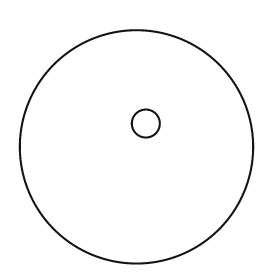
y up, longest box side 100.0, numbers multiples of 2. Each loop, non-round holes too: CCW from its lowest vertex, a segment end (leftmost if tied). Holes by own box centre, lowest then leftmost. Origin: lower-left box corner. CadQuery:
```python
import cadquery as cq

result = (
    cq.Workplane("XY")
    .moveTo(50.0, 50.0)
    .circle(50.0)
    .moveTo(54.0, 60.0)
    .circle(6.0)
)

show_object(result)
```